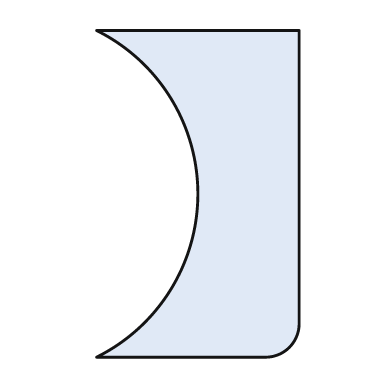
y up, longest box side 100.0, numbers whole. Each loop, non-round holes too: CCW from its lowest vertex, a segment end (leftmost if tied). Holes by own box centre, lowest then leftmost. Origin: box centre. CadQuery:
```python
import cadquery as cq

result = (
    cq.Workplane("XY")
    .moveTo(-31.0, -50.0)
    .lineTo(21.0, -50.0)
    .threePointArc((28.0, -47.0), (31.0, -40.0))
    .lineTo(31.0, 50.0)
    .lineTo(-31.0, 50.0)
    .threePointArc((0.0, 0.0), (-31.0, -50.0))
    .close()
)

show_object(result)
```